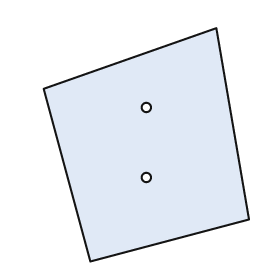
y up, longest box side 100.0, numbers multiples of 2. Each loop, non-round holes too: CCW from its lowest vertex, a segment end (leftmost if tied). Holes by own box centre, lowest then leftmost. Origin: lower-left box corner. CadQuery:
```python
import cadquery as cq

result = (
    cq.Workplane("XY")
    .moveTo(20.0, 0.0)
    .lineTo(88.0, 18.0)
    .lineTo(74.0, 100.0)
    .lineTo(0.0, 74.0)
    .close()
    .moveTo(44.0, 36.0)
    .circle(2.0)
    .moveTo(44.0, 66.0)
    .circle(2.0)
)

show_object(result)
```